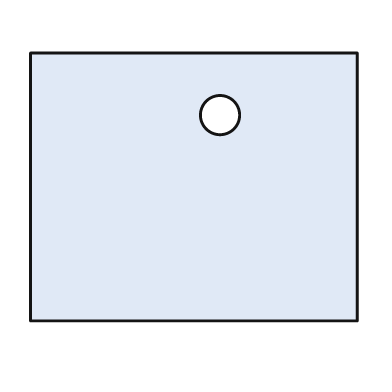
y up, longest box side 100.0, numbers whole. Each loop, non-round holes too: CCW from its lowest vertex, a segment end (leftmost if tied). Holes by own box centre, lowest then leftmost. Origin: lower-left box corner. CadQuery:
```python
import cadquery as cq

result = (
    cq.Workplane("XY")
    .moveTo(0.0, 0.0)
    .lineTo(100.0, 0.0)
    .lineTo(100.0, 82.0)
    .lineTo(0.0, 82.0)
    .close()
    .moveTo(58.0, 63.0)
    .circle(6.0)
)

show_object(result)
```